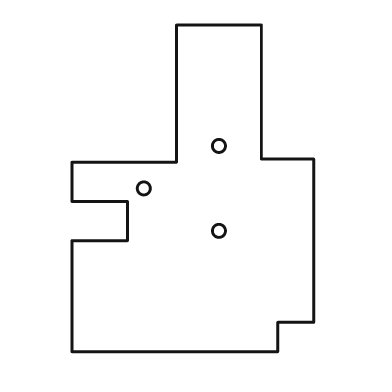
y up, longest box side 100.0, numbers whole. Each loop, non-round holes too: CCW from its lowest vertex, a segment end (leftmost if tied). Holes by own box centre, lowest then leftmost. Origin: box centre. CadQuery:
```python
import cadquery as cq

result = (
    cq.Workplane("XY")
    .moveTo(-37.0, -50.0)
    .lineTo(26.0, -50.0)
    .lineTo(26.0, -41.0)
    .lineTo(37.0, -41.0)
    .lineTo(37.0, 9.0)
    .lineTo(21.0, 9.0)
    .lineTo(21.0, 50.0)
    .lineTo(-5.0, 50.0)
    .lineTo(-5.0, 8.0)
    .lineTo(-37.0, 8.0)
    .lineTo(-37.0, -4.0)
    .lineTo(-20.0, -4.0)
    .lineTo(-20.0, -16.0)
    .lineTo(-37.0, -16.0)
    .close()
    .moveTo(8.0, -13.0)
    .circle(2.0)
    .moveTo(-15.0, 0.0)
    .circle(2.0)
    .moveTo(8.0, 13.0)
    .circle(2.0)
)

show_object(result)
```